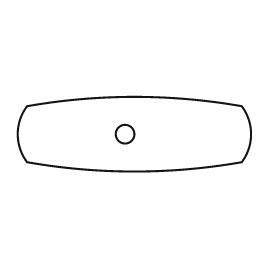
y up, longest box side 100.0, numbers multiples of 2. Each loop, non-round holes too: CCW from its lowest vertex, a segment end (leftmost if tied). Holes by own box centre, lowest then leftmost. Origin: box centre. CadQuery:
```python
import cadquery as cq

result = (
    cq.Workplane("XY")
    .moveTo(-46.0, -12.0)
    .threePointArc((0.0, -16.0), (46.0, -12.0))
    .threePointArc((50.0, 0.0), (46.0, 12.0))
    .threePointArc((0.0, 16.0), (-46.0, 12.0))
    .threePointArc((-50.0, 0.0), (-46.0, -12.0))
    .close()
    .moveTo(-4.0, 0.0)
    .circle(4.0)
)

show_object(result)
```